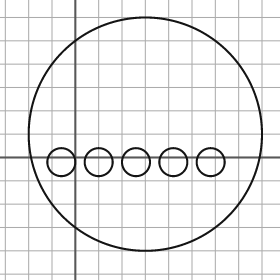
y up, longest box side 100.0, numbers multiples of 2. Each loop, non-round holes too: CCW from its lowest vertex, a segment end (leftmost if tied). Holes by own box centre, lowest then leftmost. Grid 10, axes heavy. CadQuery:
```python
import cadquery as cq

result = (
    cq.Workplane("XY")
    .moveTo(30.0, 10.0)
    .circle(50.0)
    .moveTo(-6.0, -2.0)
    .circle(6.0)
    .moveTo(10.0, -2.0)
    .circle(6.0)
    .moveTo(26.0, -2.0)
    .circle(6.0)
    .moveTo(42.0, -2.0)
    .circle(6.0)
    .moveTo(58.0, -2.0)
    .circle(6.0)
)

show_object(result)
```